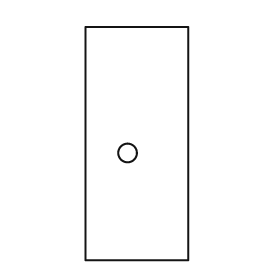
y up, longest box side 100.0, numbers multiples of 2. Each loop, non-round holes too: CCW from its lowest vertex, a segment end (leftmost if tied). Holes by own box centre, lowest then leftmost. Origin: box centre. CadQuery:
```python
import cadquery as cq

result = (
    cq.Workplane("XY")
    .moveTo(-22.0, -50.0)
    .lineTo(22.0, -50.0)
    .lineTo(22.0, 50.0)
    .lineTo(-22.0, 50.0)
    .close()
    .moveTo(-4.0, -4.0)
    .circle(4.0)
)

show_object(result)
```